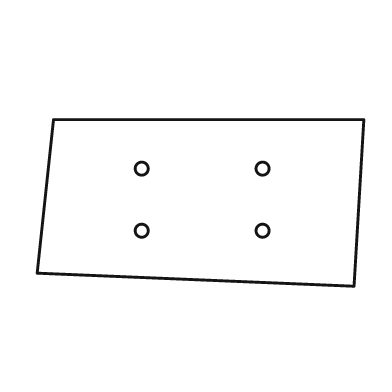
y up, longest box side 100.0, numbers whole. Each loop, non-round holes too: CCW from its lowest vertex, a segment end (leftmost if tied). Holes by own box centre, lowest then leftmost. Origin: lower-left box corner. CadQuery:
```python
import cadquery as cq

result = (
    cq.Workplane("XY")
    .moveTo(97.0, 0.0)
    .lineTo(100.0, 51.0)
    .lineTo(5.0, 51.0)
    .lineTo(0.0, 4.0)
    .close()
    .moveTo(32.0, 17.0)
    .circle(2.0)
    .moveTo(69.0, 17.0)
    .circle(2.0)
    .moveTo(32.0, 36.0)
    .circle(2.0)
    .moveTo(69.0, 36.0)
    .circle(2.0)
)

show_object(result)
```